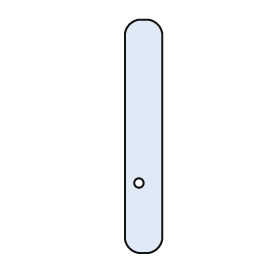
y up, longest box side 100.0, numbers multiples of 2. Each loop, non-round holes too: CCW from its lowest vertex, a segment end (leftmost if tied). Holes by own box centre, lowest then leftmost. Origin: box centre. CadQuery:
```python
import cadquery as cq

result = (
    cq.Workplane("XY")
    .moveTo(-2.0, -50.0)
    .lineTo(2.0, -50.0)
    .threePointArc((6.0, -48.0), (8.0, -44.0))
    .lineTo(8.0, 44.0)
    .threePointArc((6.0, 48.0), (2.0, 50.0))
    .lineTo(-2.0, 50.0)
    .threePointArc((-6.0, 48.0), (-8.0, 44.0))
    .lineTo(-8.0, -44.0)
    .threePointArc((-6.0, -48.0), (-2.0, -50.0))
    .close()
    .moveTo(-2.0, -20.0)
    .circle(2.0)
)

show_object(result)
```